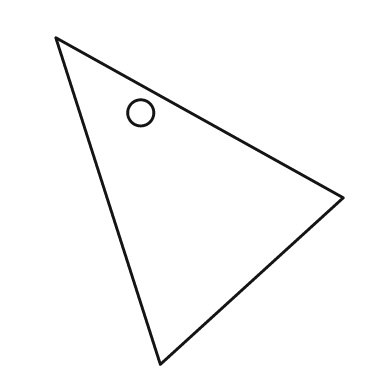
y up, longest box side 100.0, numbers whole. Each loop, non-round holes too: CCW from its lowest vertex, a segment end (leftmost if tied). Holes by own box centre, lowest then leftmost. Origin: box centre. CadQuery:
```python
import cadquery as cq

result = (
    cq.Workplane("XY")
    .moveTo(-12.0, -50.0)
    .lineTo(44.0, 1.0)
    .lineTo(-44.0, 50.0)
    .close()
    .moveTo(-18.0, 27.0)
    .circle(4.0)
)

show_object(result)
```